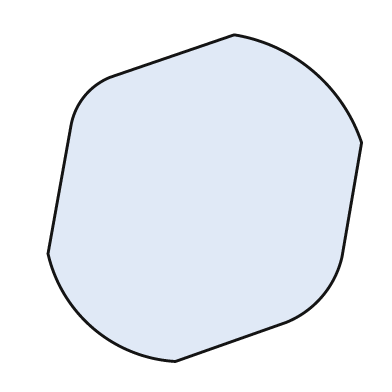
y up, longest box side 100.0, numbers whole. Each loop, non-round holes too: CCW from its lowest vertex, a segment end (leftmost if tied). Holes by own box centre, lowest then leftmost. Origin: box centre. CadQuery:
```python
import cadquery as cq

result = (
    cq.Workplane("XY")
    .moveTo(-9.0, -50.0)
    .lineTo(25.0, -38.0)
    .threePointArc((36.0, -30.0), (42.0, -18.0))
    .lineTo(48.0, 17.0)
    .threePointArc((33.0, 39.0), (9.0, 50.0))
    .lineTo(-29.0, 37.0)
    .threePointArc((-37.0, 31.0), (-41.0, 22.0))
    .lineTo(-48.0, -17.0)
    .threePointArc((-34.0, -40.0), (-9.0, -50.0))
    .close()
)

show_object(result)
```